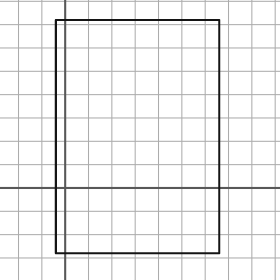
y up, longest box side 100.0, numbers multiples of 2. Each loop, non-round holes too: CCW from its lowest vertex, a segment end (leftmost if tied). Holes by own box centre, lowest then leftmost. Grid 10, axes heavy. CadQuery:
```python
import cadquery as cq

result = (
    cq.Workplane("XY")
    .moveTo(-4.0, -28.0)
    .lineTo(66.0, -28.0)
    .lineTo(66.0, 72.0)
    .lineTo(-4.0, 72.0)
    .close()
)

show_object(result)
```